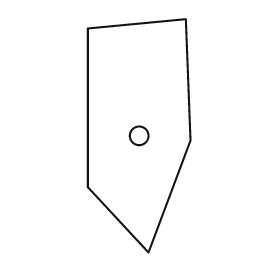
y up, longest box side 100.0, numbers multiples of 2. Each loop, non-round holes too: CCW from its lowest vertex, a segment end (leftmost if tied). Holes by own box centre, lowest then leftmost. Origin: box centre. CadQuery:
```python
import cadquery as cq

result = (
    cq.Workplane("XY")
    .moveTo(4.0, -50.0)
    .lineTo(22.0, -2.0)
    .lineTo(20.0, 50.0)
    .lineTo(-22.0, 46.0)
    .lineTo(-22.0, -22.0)
    .close()
    .moveTo(0.0, 0.0)
    .circle(4.0)
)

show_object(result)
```